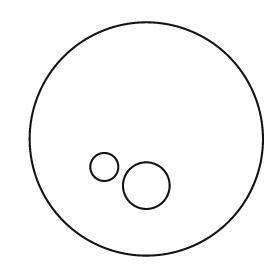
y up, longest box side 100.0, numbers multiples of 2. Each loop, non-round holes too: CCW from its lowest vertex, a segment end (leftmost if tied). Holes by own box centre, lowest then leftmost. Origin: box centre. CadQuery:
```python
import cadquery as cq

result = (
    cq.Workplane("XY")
    .moveTo(0.0, 0.0)
    .circle(50.0)
    .moveTo(0.0, -20.0)
    .circle(10.0)
    .moveTo(-18.0, -12.0)
    .circle(6.0)
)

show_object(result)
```